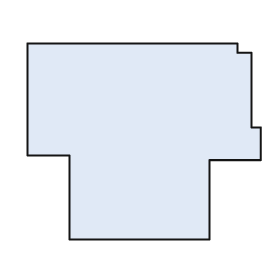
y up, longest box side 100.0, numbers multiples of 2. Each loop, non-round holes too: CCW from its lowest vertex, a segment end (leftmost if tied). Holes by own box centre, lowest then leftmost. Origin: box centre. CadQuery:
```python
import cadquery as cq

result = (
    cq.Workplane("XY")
    .moveTo(-32.0, -42.0)
    .lineTo(28.0, -42.0)
    .lineTo(28.0, -8.0)
    .lineTo(50.0, -8.0)
    .lineTo(50.0, 6.0)
    .lineTo(46.0, 6.0)
    .lineTo(46.0, 38.0)
    .lineTo(40.0, 38.0)
    .lineTo(40.0, 42.0)
    .lineTo(-50.0, 42.0)
    .lineTo(-50.0, -6.0)
    .lineTo(-32.0, -6.0)
    .close()
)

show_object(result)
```